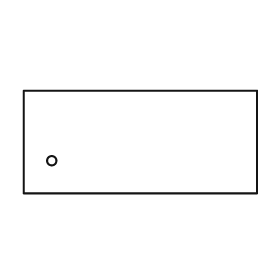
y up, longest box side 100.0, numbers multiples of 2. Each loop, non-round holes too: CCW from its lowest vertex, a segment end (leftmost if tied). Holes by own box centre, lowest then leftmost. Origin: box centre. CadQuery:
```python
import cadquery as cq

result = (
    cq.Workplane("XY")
    .moveTo(-50.0, -22.0)
    .lineTo(50.0, -22.0)
    .lineTo(50.0, 22.0)
    .lineTo(-50.0, 22.0)
    .close()
    .moveTo(-38.0, -8.0)
    .circle(2.0)
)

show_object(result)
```